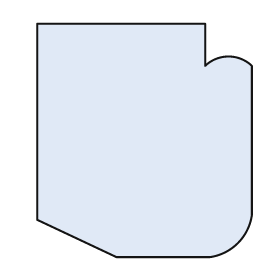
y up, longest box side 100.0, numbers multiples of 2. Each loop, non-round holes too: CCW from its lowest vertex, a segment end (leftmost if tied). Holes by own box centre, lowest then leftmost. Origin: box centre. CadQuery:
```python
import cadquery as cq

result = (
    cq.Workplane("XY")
    .moveTo(-12.0, -50.0)
    .lineTo(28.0, -50.0)
    .threePointArc((40.0, -44.0), (46.0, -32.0))
    .lineTo(46.0, 32.0)
    .threePointArc((36.0, 36.0), (26.0, 32.0))
    .lineTo(26.0, 50.0)
    .lineTo(-46.0, 50.0)
    .lineTo(-46.0, -34.0)
    .close()
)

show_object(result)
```